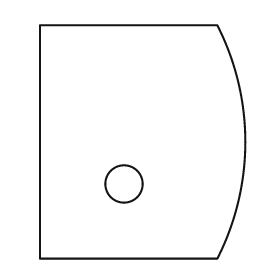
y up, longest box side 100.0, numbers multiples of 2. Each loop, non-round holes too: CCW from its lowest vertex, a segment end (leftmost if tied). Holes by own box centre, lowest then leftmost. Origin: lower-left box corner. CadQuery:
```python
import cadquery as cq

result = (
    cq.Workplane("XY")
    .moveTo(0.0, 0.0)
    .lineTo(76.0, 0.0)
    .threePointArc((88.0, 50.0), (76.0, 100.0))
    .lineTo(0.0, 100.0)
    .close()
    .moveTo(36.0, 32.0)
    .circle(8.0)
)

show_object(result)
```